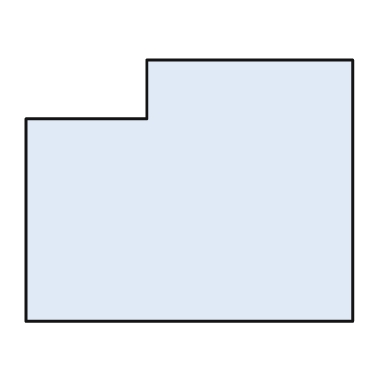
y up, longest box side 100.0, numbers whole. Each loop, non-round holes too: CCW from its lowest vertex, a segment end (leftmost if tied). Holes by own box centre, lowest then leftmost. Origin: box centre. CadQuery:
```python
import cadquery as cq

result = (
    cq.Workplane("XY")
    .moveTo(-50.0, -40.0)
    .lineTo(50.0, -40.0)
    .lineTo(50.0, 40.0)
    .lineTo(-13.0, 40.0)
    .lineTo(-13.0, 22.0)
    .lineTo(-50.0, 22.0)
    .close()
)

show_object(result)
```